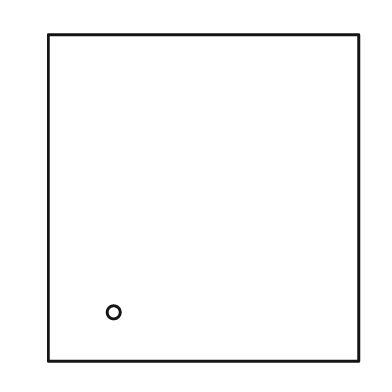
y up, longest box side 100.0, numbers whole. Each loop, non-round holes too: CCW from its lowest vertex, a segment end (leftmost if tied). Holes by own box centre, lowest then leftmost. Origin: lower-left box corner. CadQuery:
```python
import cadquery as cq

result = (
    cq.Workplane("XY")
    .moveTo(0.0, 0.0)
    .lineTo(95.0, 0.0)
    .lineTo(95.0, 100.0)
    .lineTo(0.0, 100.0)
    .close()
    .moveTo(20.0, 15.0)
    .circle(2.0)
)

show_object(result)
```